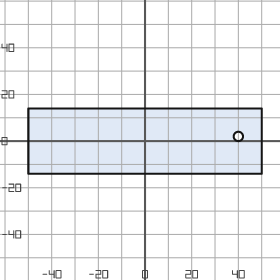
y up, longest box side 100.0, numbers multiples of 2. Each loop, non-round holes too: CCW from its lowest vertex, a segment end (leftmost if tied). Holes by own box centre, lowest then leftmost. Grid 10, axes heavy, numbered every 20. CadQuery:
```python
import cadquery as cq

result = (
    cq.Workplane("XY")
    .moveTo(-50.0, -14.0)
    .lineTo(50.0, -14.0)
    .lineTo(50.0, 14.0)
    .lineTo(-50.0, 14.0)
    .close()
    .moveTo(40.0, 2.0)
    .circle(2.0)
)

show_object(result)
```